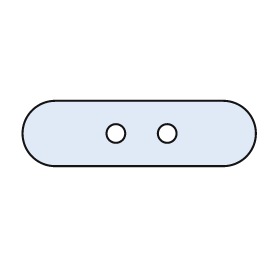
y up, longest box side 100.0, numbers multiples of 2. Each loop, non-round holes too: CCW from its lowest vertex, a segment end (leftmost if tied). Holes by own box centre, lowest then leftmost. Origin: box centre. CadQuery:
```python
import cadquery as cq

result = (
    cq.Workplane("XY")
    .moveTo(-36.0, -14.0)
    .lineTo(36.0, -14.0)
    .threePointArc((50.0, 0.0), (36.0, 14.0))
    .lineTo(-36.0, 14.0)
    .threePointArc((-50.0, 0.0), (-36.0, -14.0))
    .close()
    .moveTo(-10.0, 0.0)
    .circle(4.0)
    .moveTo(12.0, 0.0)
    .circle(4.0)
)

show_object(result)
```